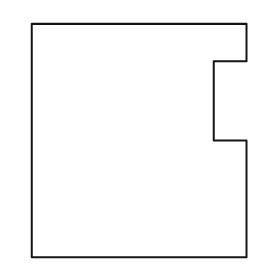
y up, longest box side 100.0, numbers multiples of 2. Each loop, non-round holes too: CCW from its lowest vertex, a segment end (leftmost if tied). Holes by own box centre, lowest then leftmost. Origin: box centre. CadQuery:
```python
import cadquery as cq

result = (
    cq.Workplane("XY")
    .moveTo(-46.0, -50.0)
    .lineTo(46.0, -50.0)
    .lineTo(46.0, 0.0)
    .lineTo(32.0, 0.0)
    .lineTo(32.0, 34.0)
    .lineTo(46.0, 34.0)
    .lineTo(46.0, 50.0)
    .lineTo(-46.0, 50.0)
    .close()
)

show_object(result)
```